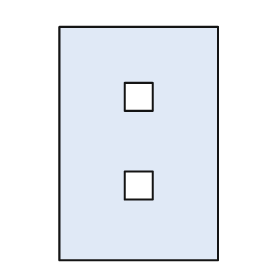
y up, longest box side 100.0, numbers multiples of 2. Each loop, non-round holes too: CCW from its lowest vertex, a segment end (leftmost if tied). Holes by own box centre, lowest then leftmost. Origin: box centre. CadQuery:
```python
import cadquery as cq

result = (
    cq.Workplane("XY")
    .moveTo(-34.0, -50.0)
    .lineTo(34.0, -50.0)
    .lineTo(34.0, 50.0)
    .lineTo(-34.0, 50.0)
    .close()
    .moveTo(-6.0, -24.0)
    .lineTo(6.0, -24.0)
    .lineTo(6.0, -12.0)
    .lineTo(-6.0, -12.0)
    .close()
    .moveTo(-6.0, 14.0)
    .lineTo(6.0, 14.0)
    .lineTo(6.0, 26.0)
    .lineTo(-6.0, 26.0)
    .close()
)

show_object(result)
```